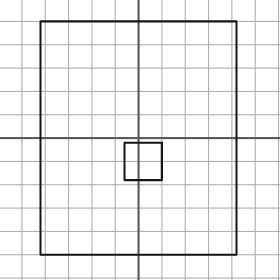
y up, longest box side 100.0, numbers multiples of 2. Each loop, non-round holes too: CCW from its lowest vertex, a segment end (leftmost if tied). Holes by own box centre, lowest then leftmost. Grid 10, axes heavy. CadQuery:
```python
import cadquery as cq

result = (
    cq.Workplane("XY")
    .moveTo(-42.0, -50.0)
    .lineTo(42.0, -50.0)
    .lineTo(42.0, 50.0)
    .lineTo(-42.0, 50.0)
    .close()
    .moveTo(-6.0, -18.0)
    .lineTo(10.0, -18.0)
    .lineTo(10.0, -2.0)
    .lineTo(-6.0, -2.0)
    .close()
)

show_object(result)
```